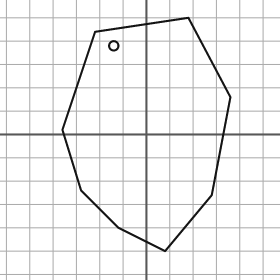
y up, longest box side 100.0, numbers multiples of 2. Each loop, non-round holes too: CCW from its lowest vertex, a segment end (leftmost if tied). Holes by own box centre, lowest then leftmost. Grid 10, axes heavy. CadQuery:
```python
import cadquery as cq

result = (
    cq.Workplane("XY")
    .moveTo(8.0, -50.0)
    .lineTo(28.0, -26.0)
    .lineTo(36.0, 16.0)
    .lineTo(18.0, 50.0)
    .lineTo(-22.0, 44.0)
    .lineTo(-36.0, 2.0)
    .lineTo(-28.0, -24.0)
    .lineTo(-12.0, -40.0)
    .close()
    .moveTo(-14.0, 38.0)
    .circle(2.0)
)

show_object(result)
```